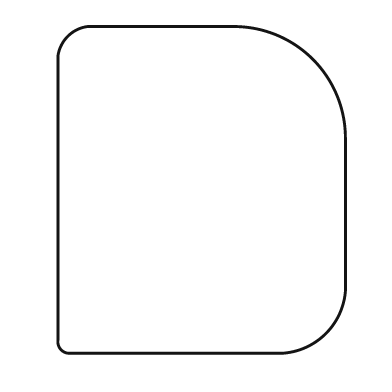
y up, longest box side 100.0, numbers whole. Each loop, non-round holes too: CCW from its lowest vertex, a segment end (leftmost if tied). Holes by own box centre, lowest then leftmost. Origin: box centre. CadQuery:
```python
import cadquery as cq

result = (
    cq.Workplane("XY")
    .moveTo(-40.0, -50.0)
    .lineTo(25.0, -50.0)
    .threePointArc((38.0, -44.0), (44.0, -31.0))
    .lineTo(44.0, 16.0)
    .threePointArc((34.0, 40.0), (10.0, 50.0))
    .lineTo(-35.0, 50.0)
    .threePointArc((-41.0, 47.0), (-44.0, 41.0))
    .lineTo(-44.0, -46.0)
    .threePointArc((-43.0, -49.0), (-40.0, -50.0))
    .close()
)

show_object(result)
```